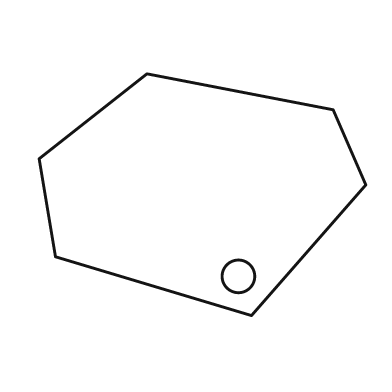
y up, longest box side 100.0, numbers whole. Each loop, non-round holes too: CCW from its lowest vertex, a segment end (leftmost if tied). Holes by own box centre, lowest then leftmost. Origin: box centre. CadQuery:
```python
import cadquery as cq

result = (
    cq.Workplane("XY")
    .moveTo(15.0, -37.0)
    .lineTo(50.0, 3.0)
    .lineTo(40.0, 26.0)
    .lineTo(-17.0, 37.0)
    .lineTo(-50.0, 11.0)
    .lineTo(-45.0, -19.0)
    .close()
    .moveTo(11.0, -25.0)
    .circle(5.0)
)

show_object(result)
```